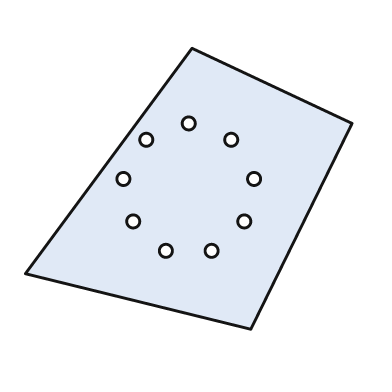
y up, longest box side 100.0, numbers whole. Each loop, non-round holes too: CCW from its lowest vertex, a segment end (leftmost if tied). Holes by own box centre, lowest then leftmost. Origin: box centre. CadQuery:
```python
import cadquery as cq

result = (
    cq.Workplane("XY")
    .moveTo(19.0, -43.0)
    .lineTo(50.0, 20.0)
    .lineTo(1.0, 43.0)
    .lineTo(-50.0, -26.0)
    .close()
    .moveTo(-7.0, -19.0)
    .circle(2.0)
    .moveTo(7.0, -19.0)
    .circle(2.0)
    .moveTo(-17.0, -10.0)
    .circle(2.0)
    .moveTo(17.0, -10.0)
    .circle(2.0)
    .moveTo(-20.0, 3.0)
    .circle(2.0)
    .moveTo(20.0, 3.0)
    .circle(2.0)
    .moveTo(-13.0, 15.0)
    .circle(2.0)
    .moveTo(13.0, 15.0)
    .circle(2.0)
    .moveTo(0.0, 20.0)
    .circle(2.0)
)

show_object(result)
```